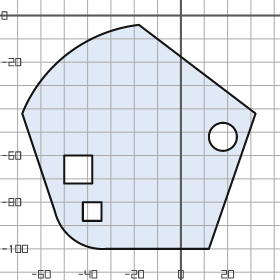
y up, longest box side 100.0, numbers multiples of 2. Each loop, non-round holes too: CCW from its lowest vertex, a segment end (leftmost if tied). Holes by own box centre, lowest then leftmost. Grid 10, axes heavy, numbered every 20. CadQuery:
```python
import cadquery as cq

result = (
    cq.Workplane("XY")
    .moveTo(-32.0, -100.0)
    .lineTo(12.0, -100.0)
    .lineTo(32.0, -42.0)
    .lineTo(-18.0, -4.0)
    .threePointArc((-48.0, -16.0), (-68.0, -42.0))
    .lineTo(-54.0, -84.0)
    .threePointArc((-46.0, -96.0), (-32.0, -100.0))
    .close()
    .moveTo(-42.0, -88.0)
    .lineTo(-34.0, -88.0)
    .lineTo(-34.0, -80.0)
    .lineTo(-42.0, -80.0)
    .close()
    .moveTo(-50.0, -72.0)
    .lineTo(-38.0, -72.0)
    .lineTo(-38.0, -60.0)
    .lineTo(-50.0, -60.0)
    .close()
    .moveTo(18.0, -52.0)
    .circle(6.0)
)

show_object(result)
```